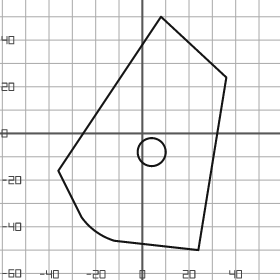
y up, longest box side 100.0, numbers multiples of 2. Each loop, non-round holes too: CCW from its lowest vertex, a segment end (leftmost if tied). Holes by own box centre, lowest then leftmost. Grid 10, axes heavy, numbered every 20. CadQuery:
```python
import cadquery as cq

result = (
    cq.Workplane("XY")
    .moveTo(24.0, -50.0)
    .lineTo(36.0, 24.0)
    .lineTo(8.0, 50.0)
    .lineTo(-36.0, -16.0)
    .lineTo(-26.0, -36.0)
    .threePointArc((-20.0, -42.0), (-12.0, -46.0))
    .close()
    .moveTo(4.0, -8.0)
    .circle(6.0)
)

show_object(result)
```